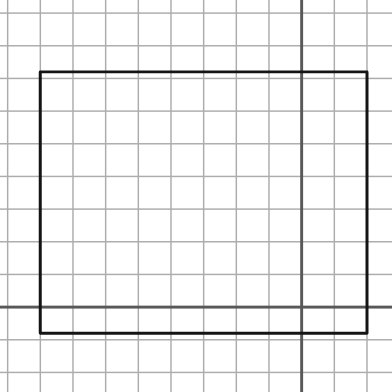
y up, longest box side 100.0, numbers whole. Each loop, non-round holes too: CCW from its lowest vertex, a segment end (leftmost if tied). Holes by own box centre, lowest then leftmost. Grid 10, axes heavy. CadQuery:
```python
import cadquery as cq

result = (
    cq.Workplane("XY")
    .moveTo(-80.0, -8.0)
    .lineTo(20.0, -8.0)
    .lineTo(20.0, 72.0)
    .lineTo(-80.0, 72.0)
    .close()
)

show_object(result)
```